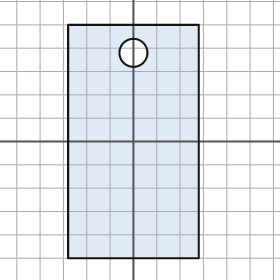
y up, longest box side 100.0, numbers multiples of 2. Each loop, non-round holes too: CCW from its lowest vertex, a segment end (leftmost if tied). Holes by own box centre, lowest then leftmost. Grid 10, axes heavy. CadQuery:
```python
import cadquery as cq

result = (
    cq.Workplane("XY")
    .moveTo(-28.0, -50.0)
    .lineTo(28.0, -50.0)
    .lineTo(28.0, 50.0)
    .lineTo(-28.0, 50.0)
    .close()
    .moveTo(0.0, 38.0)
    .circle(6.0)
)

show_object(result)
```